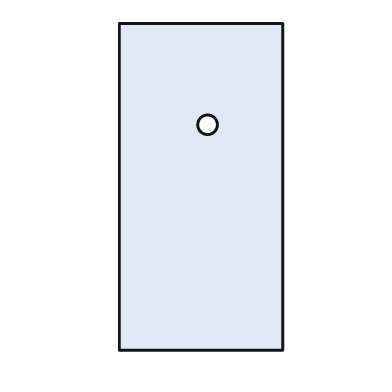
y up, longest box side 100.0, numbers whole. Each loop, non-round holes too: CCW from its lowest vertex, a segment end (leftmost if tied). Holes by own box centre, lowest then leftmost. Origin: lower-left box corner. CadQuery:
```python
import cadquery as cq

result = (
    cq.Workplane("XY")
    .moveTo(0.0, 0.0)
    .lineTo(50.0, 0.0)
    .lineTo(50.0, 100.0)
    .lineTo(0.0, 100.0)
    .close()
    .moveTo(27.0, 69.0)
    .circle(3.0)
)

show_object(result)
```